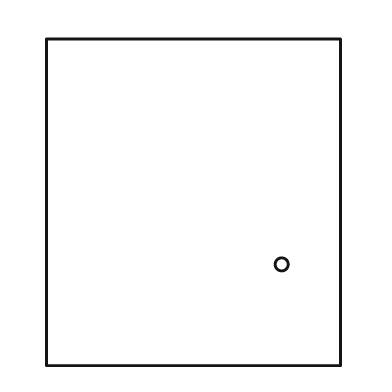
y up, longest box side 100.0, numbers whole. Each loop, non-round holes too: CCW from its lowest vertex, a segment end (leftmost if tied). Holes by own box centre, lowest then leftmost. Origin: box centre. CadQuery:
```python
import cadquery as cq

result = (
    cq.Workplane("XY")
    .moveTo(-45.0, -50.0)
    .lineTo(45.0, -50.0)
    .lineTo(45.0, 50.0)
    .lineTo(-45.0, 50.0)
    .close()
    .moveTo(27.0, -19.0)
    .circle(2.0)
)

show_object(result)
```